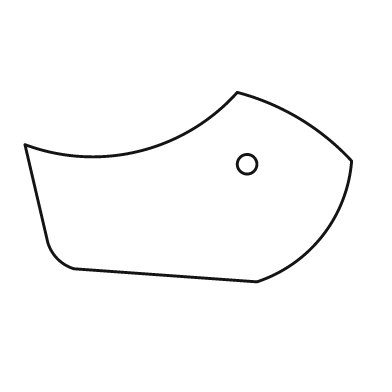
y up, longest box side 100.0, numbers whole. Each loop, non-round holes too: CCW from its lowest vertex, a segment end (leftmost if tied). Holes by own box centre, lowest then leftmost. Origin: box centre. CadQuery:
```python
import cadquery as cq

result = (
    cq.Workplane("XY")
    .moveTo(21.0, -29.0)
    .threePointArc((41.0, -15.0), (50.0, 8.0))
    .threePointArc((34.0, 21.0), (15.0, 29.0))
    .threePointArc((-15.0, 11.0), (-50.0, 13.0))
    .lineTo(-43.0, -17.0)
    .threePointArc((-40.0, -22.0), (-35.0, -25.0))
    .close()
    .moveTo(18.0, 7.0)
    .circle(3.0)
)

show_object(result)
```